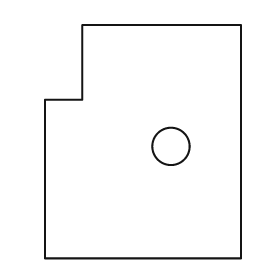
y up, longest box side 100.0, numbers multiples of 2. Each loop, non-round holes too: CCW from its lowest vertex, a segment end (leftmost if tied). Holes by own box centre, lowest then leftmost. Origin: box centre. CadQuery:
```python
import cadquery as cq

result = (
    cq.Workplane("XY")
    .moveTo(-42.0, -50.0)
    .lineTo(42.0, -50.0)
    .lineTo(42.0, 50.0)
    .lineTo(-26.0, 50.0)
    .lineTo(-26.0, 18.0)
    .lineTo(-42.0, 18.0)
    .close()
    .moveTo(12.0, -2.0)
    .circle(8.0)
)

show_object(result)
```